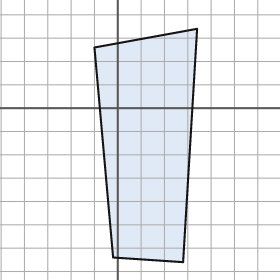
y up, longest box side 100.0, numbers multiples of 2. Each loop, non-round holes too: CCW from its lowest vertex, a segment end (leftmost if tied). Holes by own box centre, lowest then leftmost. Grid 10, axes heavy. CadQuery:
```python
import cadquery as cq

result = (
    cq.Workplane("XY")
    .moveTo(28.0, -66.0)
    .lineTo(34.0, 34.0)
    .lineTo(-10.0, 26.0)
    .lineTo(-2.0, -64.0)
    .close()
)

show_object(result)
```